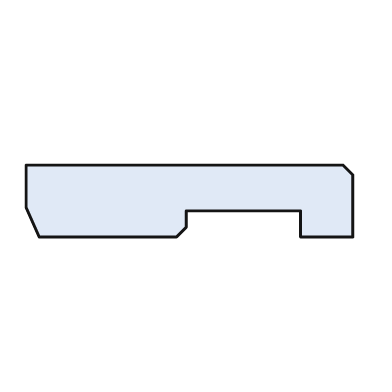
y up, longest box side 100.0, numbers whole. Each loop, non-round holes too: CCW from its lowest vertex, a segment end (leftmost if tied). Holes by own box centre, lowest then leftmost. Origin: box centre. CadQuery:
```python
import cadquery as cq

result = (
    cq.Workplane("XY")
    .moveTo(-46.0, -11.0)
    .lineTo(-4.0, -11.0)
    .lineTo(-1.0, -8.0)
    .lineTo(-1.0, -3.0)
    .lineTo(34.0, -3.0)
    .lineTo(34.0, -11.0)
    .lineTo(50.0, -11.0)
    .lineTo(50.0, 8.0)
    .lineTo(47.0, 11.0)
    .lineTo(-50.0, 11.0)
    .lineTo(-50.0, -2.0)
    .close()
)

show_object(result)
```